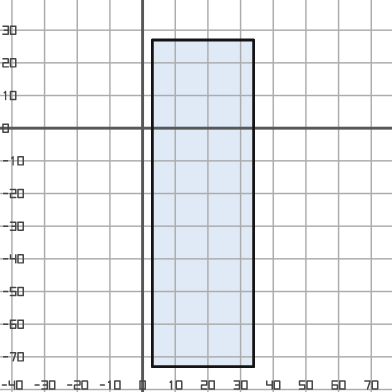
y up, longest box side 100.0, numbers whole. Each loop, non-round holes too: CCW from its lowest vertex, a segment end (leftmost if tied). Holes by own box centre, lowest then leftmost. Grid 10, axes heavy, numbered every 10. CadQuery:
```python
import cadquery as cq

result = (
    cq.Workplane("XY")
    .moveTo(3.0, -73.0)
    .lineTo(34.0, -73.0)
    .lineTo(34.0, 27.0)
    .lineTo(3.0, 27.0)
    .close()
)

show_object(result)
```